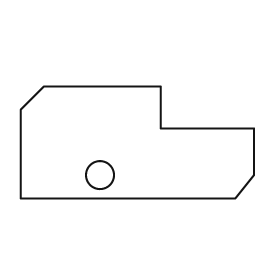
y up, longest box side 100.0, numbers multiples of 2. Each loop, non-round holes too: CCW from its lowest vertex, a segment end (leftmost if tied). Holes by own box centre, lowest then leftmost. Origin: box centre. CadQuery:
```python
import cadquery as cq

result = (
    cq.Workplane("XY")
    .moveTo(-50.0, -24.0)
    .lineTo(42.0, -24.0)
    .lineTo(50.0, -14.0)
    .lineTo(50.0, 6.0)
    .lineTo(10.0, 6.0)
    .lineTo(10.0, 24.0)
    .lineTo(-40.0, 24.0)
    .lineTo(-50.0, 14.0)
    .close()
    .moveTo(-16.0, -14.0)
    .circle(6.0)
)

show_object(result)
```